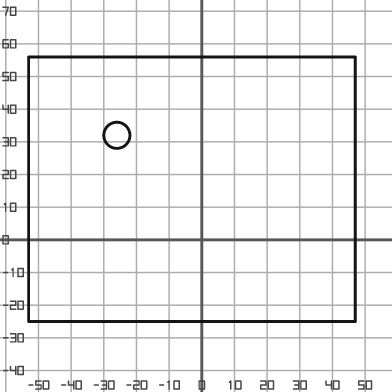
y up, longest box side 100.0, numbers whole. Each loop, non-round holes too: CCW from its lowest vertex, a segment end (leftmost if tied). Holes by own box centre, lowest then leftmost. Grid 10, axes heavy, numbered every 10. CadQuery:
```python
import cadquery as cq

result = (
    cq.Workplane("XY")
    .moveTo(-53.0, -25.0)
    .lineTo(47.0, -25.0)
    .lineTo(47.0, 56.0)
    .lineTo(-53.0, 56.0)
    .close()
    .moveTo(-26.0, 32.0)
    .circle(4.0)
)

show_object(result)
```